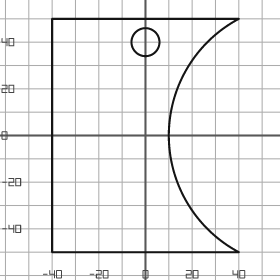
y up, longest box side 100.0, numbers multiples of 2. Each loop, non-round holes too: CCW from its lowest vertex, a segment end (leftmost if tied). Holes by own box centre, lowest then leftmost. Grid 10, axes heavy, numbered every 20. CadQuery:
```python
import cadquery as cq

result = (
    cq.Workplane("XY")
    .moveTo(-40.0, -50.0)
    .lineTo(40.0, -50.0)
    .threePointArc((10.0, 0.0), (40.0, 50.0))
    .lineTo(-40.0, 50.0)
    .close()
    .moveTo(0.0, 40.0)
    .circle(6.0)
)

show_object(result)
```